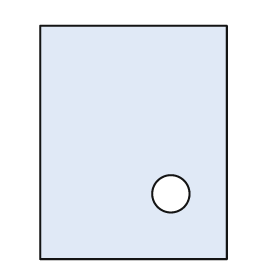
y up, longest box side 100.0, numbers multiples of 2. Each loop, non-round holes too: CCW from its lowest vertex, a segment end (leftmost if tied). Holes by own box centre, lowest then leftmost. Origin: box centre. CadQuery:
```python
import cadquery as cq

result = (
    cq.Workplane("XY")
    .moveTo(-40.0, -50.0)
    .lineTo(40.0, -50.0)
    .lineTo(40.0, 50.0)
    .lineTo(-40.0, 50.0)
    .close()
    .moveTo(16.0, -22.0)
    .circle(8.0)
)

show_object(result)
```